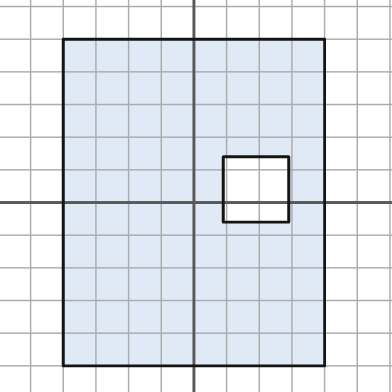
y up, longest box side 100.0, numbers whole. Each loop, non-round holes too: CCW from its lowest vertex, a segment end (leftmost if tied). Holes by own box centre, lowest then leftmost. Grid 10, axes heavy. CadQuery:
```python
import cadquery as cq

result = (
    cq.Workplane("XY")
    .moveTo(-40.0, -50.0)
    .lineTo(40.0, -50.0)
    .lineTo(40.0, 50.0)
    .lineTo(-40.0, 50.0)
    .close()
    .moveTo(9.0, -6.0)
    .lineTo(29.0, -6.0)
    .lineTo(29.0, 14.0)
    .lineTo(9.0, 14.0)
    .close()
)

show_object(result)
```